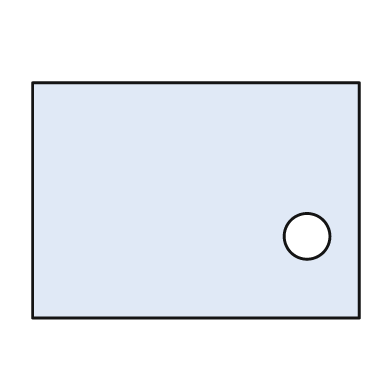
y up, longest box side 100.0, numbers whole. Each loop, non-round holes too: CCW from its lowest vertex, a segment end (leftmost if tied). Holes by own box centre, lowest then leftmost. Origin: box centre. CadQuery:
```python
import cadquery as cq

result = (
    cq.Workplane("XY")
    .moveTo(-50.0, -36.0)
    .lineTo(50.0, -36.0)
    .lineTo(50.0, 36.0)
    .lineTo(-50.0, 36.0)
    .close()
    .moveTo(34.0, -11.0)
    .circle(7.0)
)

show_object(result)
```